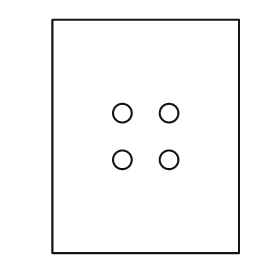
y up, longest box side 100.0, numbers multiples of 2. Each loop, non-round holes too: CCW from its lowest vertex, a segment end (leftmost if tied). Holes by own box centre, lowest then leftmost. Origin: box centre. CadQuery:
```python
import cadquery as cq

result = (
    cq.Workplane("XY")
    .moveTo(-40.0, -50.0)
    .lineTo(40.0, -50.0)
    .lineTo(40.0, 50.0)
    .lineTo(-40.0, 50.0)
    .close()
    .moveTo(-10.0, -10.0)
    .circle(4.0)
    .moveTo(10.0, -10.0)
    .circle(4.0)
    .moveTo(-10.0, 10.0)
    .circle(4.0)
    .moveTo(10.0, 10.0)
    .circle(4.0)
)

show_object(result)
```